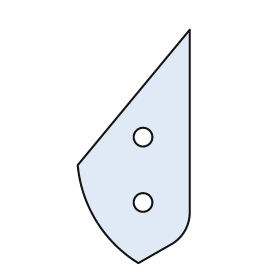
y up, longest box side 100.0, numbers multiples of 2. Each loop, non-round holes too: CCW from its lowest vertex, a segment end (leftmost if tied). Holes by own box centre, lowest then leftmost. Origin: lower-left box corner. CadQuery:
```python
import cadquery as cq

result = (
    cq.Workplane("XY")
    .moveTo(26.0, 0.0)
    .lineTo(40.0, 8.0)
    .threePointArc((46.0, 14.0), (48.0, 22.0))
    .lineTo(48.0, 100.0)
    .lineTo(0.0, 42.0)
    .threePointArc((8.0, 18.0), (26.0, 0.0))
    .close()
    .moveTo(28.0, 26.0)
    .circle(4.0)
    .moveTo(28.0, 54.0)
    .circle(4.0)
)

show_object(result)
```